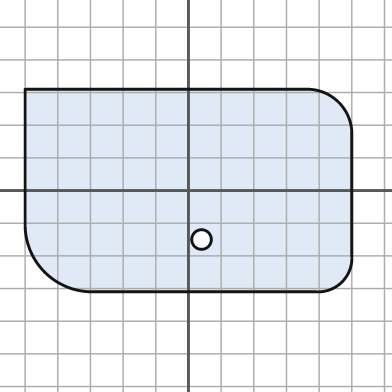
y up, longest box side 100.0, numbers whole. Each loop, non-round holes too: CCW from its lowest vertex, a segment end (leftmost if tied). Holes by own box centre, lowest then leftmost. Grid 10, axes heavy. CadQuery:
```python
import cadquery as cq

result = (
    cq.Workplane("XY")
    .moveTo(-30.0, -31.0)
    .lineTo(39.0, -31.0)
    .threePointArc((47.0, -28.0), (50.0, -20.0))
    .lineTo(50.0, 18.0)
    .threePointArc((46.0, 27.0), (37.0, 31.0))
    .lineTo(-50.0, 31.0)
    .lineTo(-50.0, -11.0)
    .threePointArc((-44.0, -25.0), (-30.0, -31.0))
    .close()
    .moveTo(4.0, -15.0)
    .circle(3.0)
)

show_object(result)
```